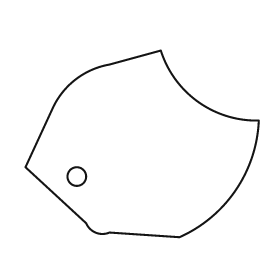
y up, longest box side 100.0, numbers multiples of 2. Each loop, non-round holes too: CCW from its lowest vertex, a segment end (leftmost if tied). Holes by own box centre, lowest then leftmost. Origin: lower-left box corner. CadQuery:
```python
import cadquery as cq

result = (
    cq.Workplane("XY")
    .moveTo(66.0, 0.0)
    .threePointArc((90.0, 20.0), (100.0, 50.0))
    .threePointArc((74.0, 58.0), (58.0, 80.0))
    .lineTo(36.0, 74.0)
    .threePointArc((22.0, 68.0), (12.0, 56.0))
    .lineTo(0.0, 30.0)
    .lineTo(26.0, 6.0)
    .threePointArc((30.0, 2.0), (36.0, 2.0))
    .close()
    .moveTo(22.0, 26.0)
    .circle(4.0)
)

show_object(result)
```